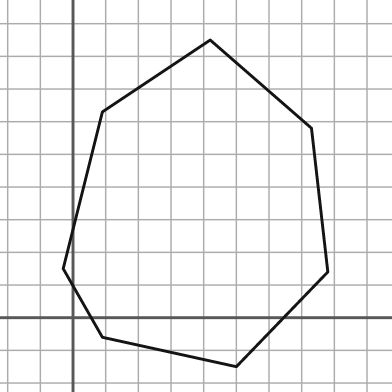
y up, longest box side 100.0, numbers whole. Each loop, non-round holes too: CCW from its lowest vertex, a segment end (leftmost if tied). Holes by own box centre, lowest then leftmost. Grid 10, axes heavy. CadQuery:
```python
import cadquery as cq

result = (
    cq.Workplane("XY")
    .moveTo(50.0, -15.0)
    .lineTo(78.0, 14.0)
    .lineTo(73.0, 58.0)
    .lineTo(42.0, 85.0)
    .lineTo(9.0, 63.0)
    .lineTo(-3.0, 15.0)
    .lineTo(9.0, -6.0)
    .close()
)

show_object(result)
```